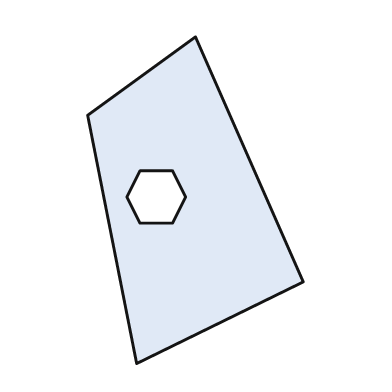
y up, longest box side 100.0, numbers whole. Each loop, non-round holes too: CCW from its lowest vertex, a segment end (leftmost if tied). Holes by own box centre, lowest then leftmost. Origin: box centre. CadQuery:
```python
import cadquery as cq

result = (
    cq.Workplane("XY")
    .moveTo(-18.0, -50.0)
    .lineTo(33.0, -25.0)
    .lineTo(0.0, 50.0)
    .lineTo(-33.0, 26.0)
    .close()
    .moveTo(-17.0, -7.0)
    .lineTo(-7.0, -7.0)
    .lineTo(-3.0, 1.0)
    .lineTo(-7.0, 9.0)
    .lineTo(-17.0, 9.0)
    .lineTo(-21.0, 1.0)
    .close()
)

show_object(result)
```